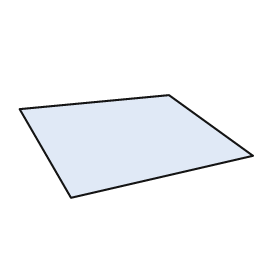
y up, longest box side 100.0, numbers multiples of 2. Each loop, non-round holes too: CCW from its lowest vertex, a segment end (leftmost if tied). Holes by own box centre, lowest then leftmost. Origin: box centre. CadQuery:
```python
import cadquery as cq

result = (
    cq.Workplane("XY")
    .moveTo(-28.0, -22.0)
    .lineTo(50.0, -4.0)
    .lineTo(14.0, 22.0)
    .lineTo(-50.0, 16.0)
    .close()
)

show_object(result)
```